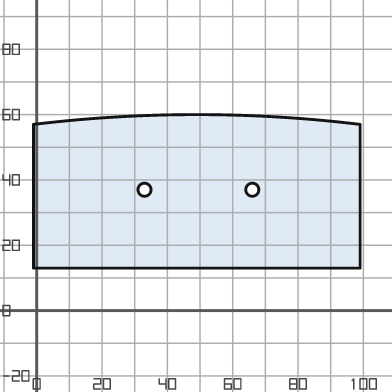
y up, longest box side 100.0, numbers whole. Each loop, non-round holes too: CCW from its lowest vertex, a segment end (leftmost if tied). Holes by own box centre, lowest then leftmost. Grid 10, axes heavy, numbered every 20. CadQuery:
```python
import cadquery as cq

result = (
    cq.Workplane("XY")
    .moveTo(-1.0, 13.0)
    .lineTo(99.0, 13.0)
    .lineTo(99.0, 57.0)
    .threePointArc((49.0, 60.0), (-1.0, 57.0))
    .close()
    .moveTo(33.0, 37.0)
    .circle(2.0)
    .moveTo(66.0, 37.0)
    .circle(2.0)
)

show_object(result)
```